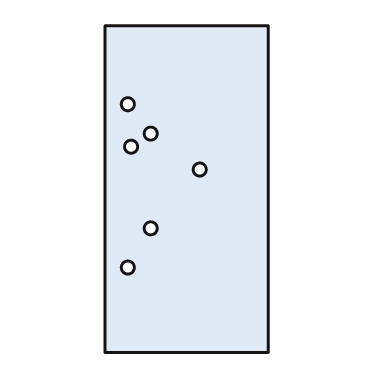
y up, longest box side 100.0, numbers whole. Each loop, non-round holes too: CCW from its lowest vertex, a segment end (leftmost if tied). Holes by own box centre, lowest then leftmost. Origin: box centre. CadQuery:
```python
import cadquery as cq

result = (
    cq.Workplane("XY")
    .moveTo(-25.0, -50.0)
    .lineTo(25.0, -50.0)
    .lineTo(25.0, 50.0)
    .lineTo(-25.0, 50.0)
    .close()
    .moveTo(-18.0, -24.0)
    .circle(2.0)
    .moveTo(-11.0, -12.0)
    .circle(2.0)
    .moveTo(4.0, 6.0)
    .circle(2.0)
    .moveTo(-17.0, 13.0)
    .circle(2.0)
    .moveTo(-11.0, 17.0)
    .circle(2.0)
    .moveTo(-18.0, 26.0)
    .circle(2.0)
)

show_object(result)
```